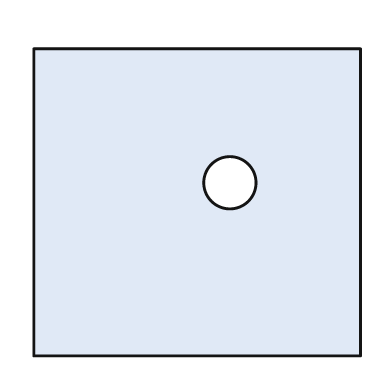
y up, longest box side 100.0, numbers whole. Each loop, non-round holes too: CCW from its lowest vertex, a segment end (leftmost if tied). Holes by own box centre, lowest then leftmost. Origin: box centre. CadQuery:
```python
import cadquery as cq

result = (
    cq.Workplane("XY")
    .moveTo(-50.0, -47.0)
    .lineTo(50.0, -47.0)
    .lineTo(50.0, 47.0)
    .lineTo(-50.0, 47.0)
    .close()
    .moveTo(10.0, 6.0)
    .circle(8.0)
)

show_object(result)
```